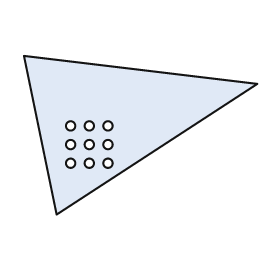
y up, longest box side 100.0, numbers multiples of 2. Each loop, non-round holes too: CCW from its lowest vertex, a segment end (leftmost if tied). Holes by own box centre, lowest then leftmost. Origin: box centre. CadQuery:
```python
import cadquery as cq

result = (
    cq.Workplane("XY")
    .moveTo(-36.0, -34.0)
    .lineTo(50.0, 22.0)
    .lineTo(-50.0, 34.0)
    .close()
    .moveTo(-30.0, -12.0)
    .circle(2.0)
    .moveTo(-22.0, -12.0)
    .circle(2.0)
    .moveTo(-14.0, -12.0)
    .circle(2.0)
    .moveTo(-30.0, -4.0)
    .circle(2.0)
    .moveTo(-22.0, -4.0)
    .circle(2.0)
    .moveTo(-14.0, -4.0)
    .circle(2.0)
    .moveTo(-30.0, 4.0)
    .circle(2.0)
    .moveTo(-22.0, 4.0)
    .circle(2.0)
    .moveTo(-14.0, 4.0)
    .circle(2.0)
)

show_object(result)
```